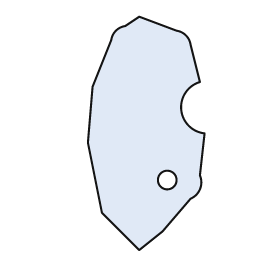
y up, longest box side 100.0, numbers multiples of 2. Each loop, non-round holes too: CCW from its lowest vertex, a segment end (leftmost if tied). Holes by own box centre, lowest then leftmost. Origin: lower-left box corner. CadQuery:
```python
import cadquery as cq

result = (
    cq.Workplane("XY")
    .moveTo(22.0, 0.0)
    .lineTo(32.0, 8.0)
    .lineTo(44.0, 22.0)
    .threePointArc((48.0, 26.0), (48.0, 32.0))
    .lineTo(50.0, 50.0)
    .threePointArc((40.0, 60.0), (48.0, 72.0))
    .lineTo(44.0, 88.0)
    .threePointArc((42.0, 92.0), (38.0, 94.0))
    .lineTo(22.0, 100.0)
    .lineTo(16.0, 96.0)
    .threePointArc((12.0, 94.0), (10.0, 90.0))
    .lineTo(2.0, 70.0)
    .lineTo(0.0, 46.0)
    .lineTo(6.0, 16.0)
    .close()
    .moveTo(34.0, 30.0)
    .circle(4.0)
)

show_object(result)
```